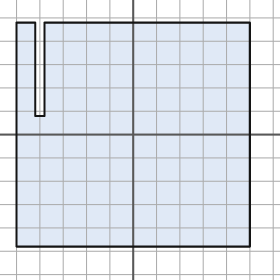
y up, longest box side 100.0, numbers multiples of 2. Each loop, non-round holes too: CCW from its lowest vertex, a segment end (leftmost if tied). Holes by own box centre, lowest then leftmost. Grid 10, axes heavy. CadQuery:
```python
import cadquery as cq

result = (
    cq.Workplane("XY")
    .moveTo(-50.0, -48.0)
    .lineTo(50.0, -48.0)
    .lineTo(50.0, 48.0)
    .lineTo(-38.0, 48.0)
    .lineTo(-38.0, 8.0)
    .lineTo(-42.0, 8.0)
    .lineTo(-42.0, 48.0)
    .lineTo(-50.0, 48.0)
    .close()
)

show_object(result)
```